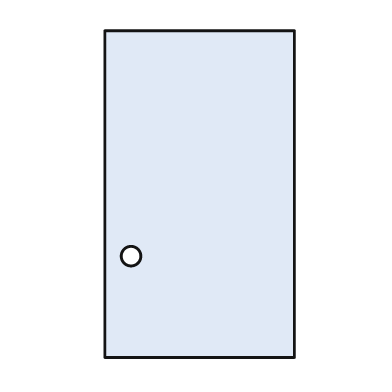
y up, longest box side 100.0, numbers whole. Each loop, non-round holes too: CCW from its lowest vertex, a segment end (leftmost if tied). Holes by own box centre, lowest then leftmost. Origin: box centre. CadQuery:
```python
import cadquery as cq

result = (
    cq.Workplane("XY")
    .moveTo(-29.0, -50.0)
    .lineTo(29.0, -50.0)
    .lineTo(29.0, 50.0)
    .lineTo(-29.0, 50.0)
    .close()
    .moveTo(-21.0, -19.0)
    .circle(3.0)
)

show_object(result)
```